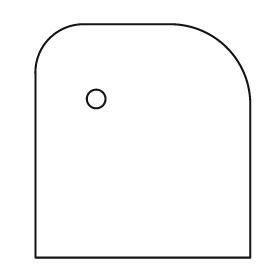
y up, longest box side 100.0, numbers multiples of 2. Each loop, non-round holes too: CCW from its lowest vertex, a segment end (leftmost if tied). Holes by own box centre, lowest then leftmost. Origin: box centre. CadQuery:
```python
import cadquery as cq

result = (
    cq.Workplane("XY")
    .moveTo(-46.0, -50.0)
    .lineTo(46.0, -50.0)
    .lineTo(46.0, 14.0)
    .threePointArc((36.0, 40.0), (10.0, 50.0))
    .lineTo(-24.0, 50.0)
    .threePointArc((-40.0, 44.0), (-46.0, 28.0))
    .close()
    .moveTo(-20.0, 18.0)
    .circle(4.0)
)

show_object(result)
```